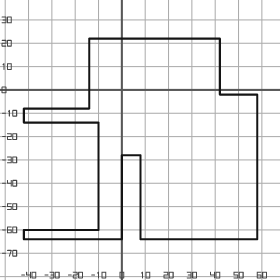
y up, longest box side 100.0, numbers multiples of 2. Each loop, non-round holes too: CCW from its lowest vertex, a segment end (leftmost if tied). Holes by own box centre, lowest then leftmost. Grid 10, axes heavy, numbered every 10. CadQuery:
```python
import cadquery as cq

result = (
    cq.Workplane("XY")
    .moveTo(-42.0, -64.0)
    .lineTo(0.0, -64.0)
    .lineTo(0.0, -28.0)
    .lineTo(8.0, -28.0)
    .lineTo(8.0, -64.0)
    .lineTo(58.0, -64.0)
    .lineTo(58.0, -2.0)
    .lineTo(42.0, -2.0)
    .lineTo(42.0, 22.0)
    .lineTo(-14.0, 22.0)
    .lineTo(-14.0, -8.0)
    .lineTo(-42.0, -8.0)
    .lineTo(-42.0, -14.0)
    .lineTo(-10.0, -14.0)
    .lineTo(-10.0, -60.0)
    .lineTo(-42.0, -60.0)
    .close()
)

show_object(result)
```